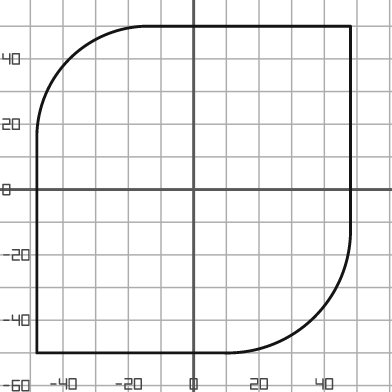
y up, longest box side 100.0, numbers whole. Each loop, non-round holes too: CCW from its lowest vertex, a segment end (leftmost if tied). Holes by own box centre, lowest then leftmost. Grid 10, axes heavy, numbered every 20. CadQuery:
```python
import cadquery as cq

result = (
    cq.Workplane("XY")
    .moveTo(-48.0, -50.0)
    .lineTo(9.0, -50.0)
    .threePointArc((37.0, -39.0), (48.0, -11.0))
    .lineTo(48.0, 50.0)
    .lineTo(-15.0, 50.0)
    .threePointArc((-38.0, 40.0), (-48.0, 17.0))
    .close()
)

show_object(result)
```